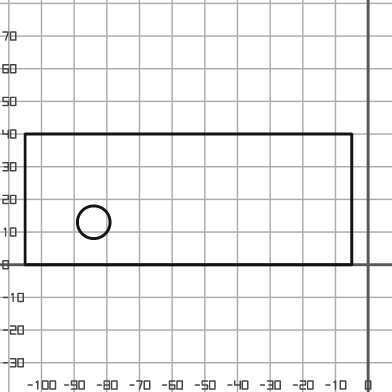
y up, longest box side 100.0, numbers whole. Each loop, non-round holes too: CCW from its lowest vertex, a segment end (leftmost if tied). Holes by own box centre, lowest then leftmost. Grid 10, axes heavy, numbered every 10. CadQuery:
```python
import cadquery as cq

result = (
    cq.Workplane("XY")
    .moveTo(-105.0, 0.0)
    .lineTo(-5.0, 0.0)
    .lineTo(-5.0, 40.0)
    .lineTo(-105.0, 40.0)
    .close()
    .moveTo(-84.0, 13.0)
    .circle(5.0)
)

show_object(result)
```